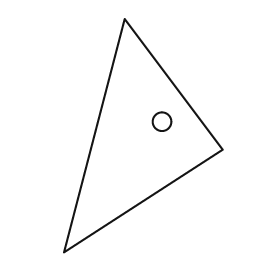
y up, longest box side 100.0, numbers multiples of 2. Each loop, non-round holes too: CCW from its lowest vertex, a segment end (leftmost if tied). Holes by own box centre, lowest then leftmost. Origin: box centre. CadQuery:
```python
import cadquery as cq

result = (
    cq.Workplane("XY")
    .moveTo(-34.0, -50.0)
    .lineTo(34.0, -6.0)
    .lineTo(-8.0, 50.0)
    .close()
    .moveTo(8.0, 6.0)
    .circle(4.0)
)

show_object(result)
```